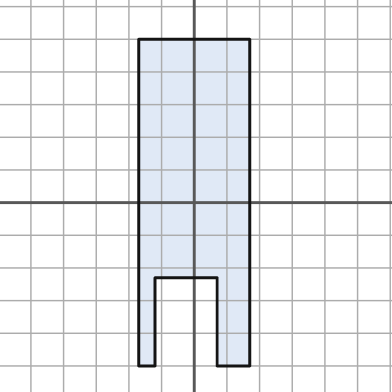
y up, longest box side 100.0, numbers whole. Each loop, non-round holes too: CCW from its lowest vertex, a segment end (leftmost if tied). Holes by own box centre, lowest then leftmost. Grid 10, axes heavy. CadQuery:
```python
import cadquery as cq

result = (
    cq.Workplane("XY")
    .moveTo(-17.0, -50.0)
    .lineTo(-12.0, -50.0)
    .lineTo(-12.0, -23.0)
    .lineTo(7.0, -23.0)
    .lineTo(7.0, -50.0)
    .lineTo(17.0, -50.0)
    .lineTo(17.0, 50.0)
    .lineTo(-17.0, 50.0)
    .close()
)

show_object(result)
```